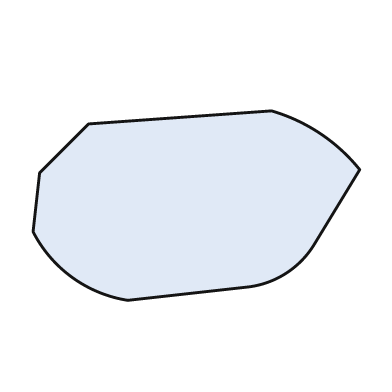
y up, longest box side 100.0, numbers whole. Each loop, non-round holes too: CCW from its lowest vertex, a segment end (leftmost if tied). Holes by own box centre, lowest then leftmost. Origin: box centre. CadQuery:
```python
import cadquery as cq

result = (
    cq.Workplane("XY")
    .moveTo(-21.0, -29.0)
    .lineTo(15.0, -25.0)
    .threePointArc((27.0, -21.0), (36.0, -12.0))
    .lineTo(50.0, 11.0)
    .threePointArc((38.0, 22.0), (23.0, 29.0))
    .lineTo(-33.0, 25.0)
    .lineTo(-48.0, 10.0)
    .lineTo(-50.0, -8.0)
    .threePointArc((-38.0, -22.0), (-21.0, -29.0))
    .close()
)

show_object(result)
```